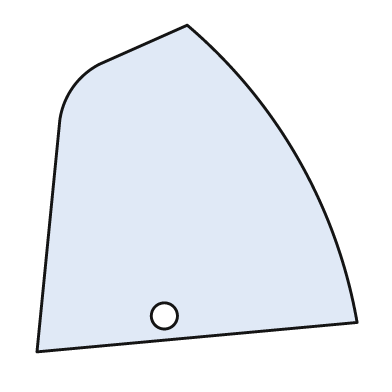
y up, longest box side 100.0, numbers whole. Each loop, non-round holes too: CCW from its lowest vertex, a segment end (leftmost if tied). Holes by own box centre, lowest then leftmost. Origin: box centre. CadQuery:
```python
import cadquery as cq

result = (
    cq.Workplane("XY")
    .moveTo(-49.0, -50.0)
    .lineTo(49.0, -41.0)
    .threePointArc((31.0, 9.0), (-3.0, 50.0))
    .lineTo(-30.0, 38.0)
    .threePointArc((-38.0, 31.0), (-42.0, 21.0))
    .close()
    .moveTo(-10.0, -39.0)
    .circle(4.0)
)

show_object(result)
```